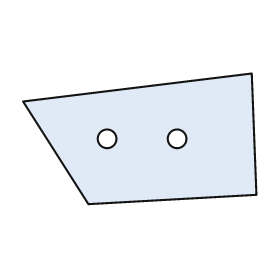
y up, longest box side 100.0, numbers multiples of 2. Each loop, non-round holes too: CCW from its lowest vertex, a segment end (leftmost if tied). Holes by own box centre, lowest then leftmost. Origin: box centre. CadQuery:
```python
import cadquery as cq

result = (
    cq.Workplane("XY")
    .moveTo(-22.0, -28.0)
    .lineTo(50.0, -24.0)
    .lineTo(48.0, 28.0)
    .lineTo(-50.0, 16.0)
    .close()
    .moveTo(-14.0, 0.0)
    .circle(4.0)
    .moveTo(16.0, 0.0)
    .circle(4.0)
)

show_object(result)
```